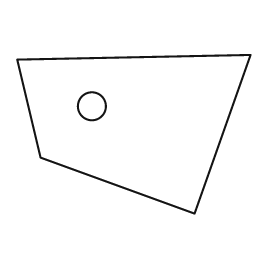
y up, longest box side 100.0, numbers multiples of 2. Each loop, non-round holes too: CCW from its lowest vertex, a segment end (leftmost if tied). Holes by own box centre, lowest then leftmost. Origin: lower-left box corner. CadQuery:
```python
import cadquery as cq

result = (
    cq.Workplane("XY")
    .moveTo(76.0, 0.0)
    .lineTo(100.0, 68.0)
    .lineTo(0.0, 66.0)
    .lineTo(10.0, 24.0)
    .close()
    .moveTo(32.0, 46.0)
    .circle(6.0)
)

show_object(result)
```